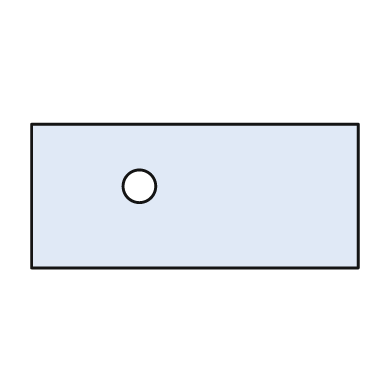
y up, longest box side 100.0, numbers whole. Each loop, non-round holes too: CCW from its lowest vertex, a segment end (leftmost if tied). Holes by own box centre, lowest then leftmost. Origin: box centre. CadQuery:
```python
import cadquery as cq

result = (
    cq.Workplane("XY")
    .moveTo(-50.0, -22.0)
    .lineTo(50.0, -22.0)
    .lineTo(50.0, 22.0)
    .lineTo(-50.0, 22.0)
    .close()
    .moveTo(-17.0, 3.0)
    .circle(5.0)
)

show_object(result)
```